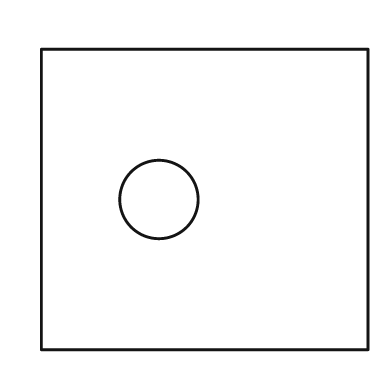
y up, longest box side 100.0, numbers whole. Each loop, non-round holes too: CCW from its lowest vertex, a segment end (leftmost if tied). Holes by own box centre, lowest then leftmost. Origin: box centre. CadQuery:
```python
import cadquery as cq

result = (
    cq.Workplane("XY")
    .moveTo(-50.0, -46.0)
    .lineTo(50.0, -46.0)
    .lineTo(50.0, 46.0)
    .lineTo(-50.0, 46.0)
    .close()
    .moveTo(-14.0, 0.0)
    .circle(12.0)
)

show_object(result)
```